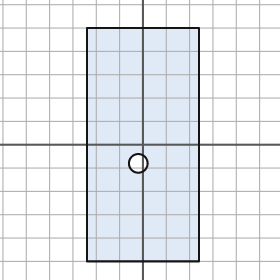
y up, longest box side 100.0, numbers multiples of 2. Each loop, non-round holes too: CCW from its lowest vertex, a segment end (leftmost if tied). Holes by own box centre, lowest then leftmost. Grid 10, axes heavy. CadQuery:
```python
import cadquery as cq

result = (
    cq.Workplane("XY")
    .moveTo(-24.0, -50.0)
    .lineTo(24.0, -50.0)
    .lineTo(24.0, 50.0)
    .lineTo(-24.0, 50.0)
    .close()
    .moveTo(-2.0, -8.0)
    .circle(4.0)
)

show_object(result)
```